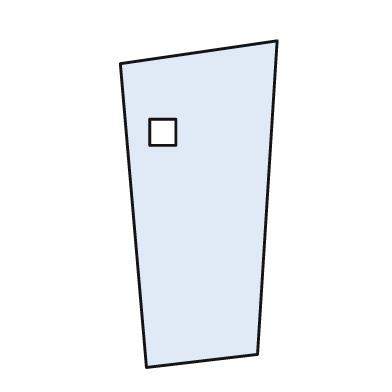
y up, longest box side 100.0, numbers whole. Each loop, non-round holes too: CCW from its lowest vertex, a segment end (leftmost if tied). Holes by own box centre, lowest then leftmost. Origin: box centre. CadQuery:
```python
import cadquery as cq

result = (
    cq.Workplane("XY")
    .moveTo(-16.0, -50.0)
    .lineTo(18.0, -46.0)
    .lineTo(24.0, 50.0)
    .lineTo(-24.0, 43.0)
    .close()
    .moveTo(-15.0, 18.0)
    .lineTo(-7.0, 18.0)
    .lineTo(-7.0, 26.0)
    .lineTo(-15.0, 26.0)
    .close()
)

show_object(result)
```